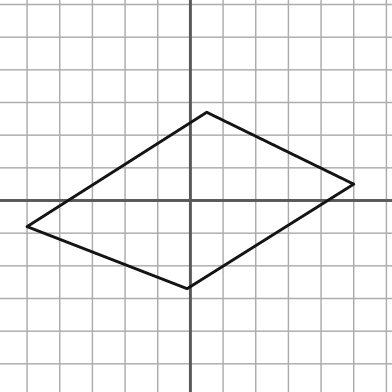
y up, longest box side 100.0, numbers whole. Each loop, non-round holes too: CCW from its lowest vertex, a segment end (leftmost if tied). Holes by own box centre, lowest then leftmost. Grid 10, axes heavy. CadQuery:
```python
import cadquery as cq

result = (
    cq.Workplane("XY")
    .moveTo(-1.0, -27.0)
    .lineTo(50.0, 5.0)
    .lineTo(5.0, 27.0)
    .lineTo(-50.0, -8.0)
    .close()
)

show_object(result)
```